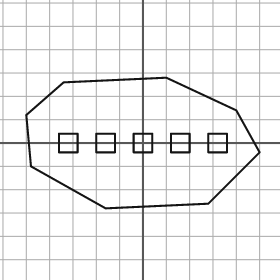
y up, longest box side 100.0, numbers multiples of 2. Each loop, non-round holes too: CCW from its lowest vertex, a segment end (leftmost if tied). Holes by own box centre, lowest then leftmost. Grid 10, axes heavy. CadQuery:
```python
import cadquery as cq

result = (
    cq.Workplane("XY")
    .moveTo(-16.0, -28.0)
    .lineTo(28.0, -26.0)
    .lineTo(50.0, -4.0)
    .lineTo(40.0, 14.0)
    .lineTo(10.0, 28.0)
    .lineTo(-34.0, 26.0)
    .lineTo(-50.0, 12.0)
    .lineTo(-48.0, -10.0)
    .close()
    .moveTo(-36.0, -4.0)
    .lineTo(-28.0, -4.0)
    .lineTo(-28.0, 4.0)
    .lineTo(-36.0, 4.0)
    .close()
    .moveTo(-20.0, -4.0)
    .lineTo(-12.0, -4.0)
    .lineTo(-12.0, 4.0)
    .lineTo(-20.0, 4.0)
    .close()
    .moveTo(-4.0, -4.0)
    .lineTo(4.0, -4.0)
    .lineTo(4.0, 4.0)
    .lineTo(-4.0, 4.0)
    .close()
    .moveTo(12.0, -4.0)
    .lineTo(20.0, -4.0)
    .lineTo(20.0, 4.0)
    .lineTo(12.0, 4.0)
    .close()
    .moveTo(28.0, -4.0)
    .lineTo(36.0, -4.0)
    .lineTo(36.0, 4.0)
    .lineTo(28.0, 4.0)
    .close()
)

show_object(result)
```